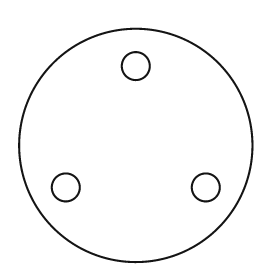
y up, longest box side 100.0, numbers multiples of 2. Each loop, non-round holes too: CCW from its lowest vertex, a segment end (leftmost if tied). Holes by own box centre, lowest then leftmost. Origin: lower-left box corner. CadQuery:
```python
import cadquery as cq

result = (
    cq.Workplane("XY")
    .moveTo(50.0, 50.0)
    .circle(50.0)
    .moveTo(20.0, 32.0)
    .circle(6.0)
    .moveTo(80.0, 32.0)
    .circle(6.0)
    .moveTo(50.0, 84.0)
    .circle(6.0)
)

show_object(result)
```